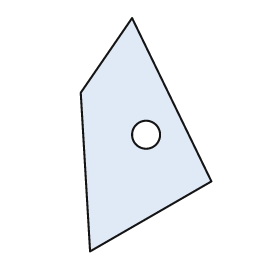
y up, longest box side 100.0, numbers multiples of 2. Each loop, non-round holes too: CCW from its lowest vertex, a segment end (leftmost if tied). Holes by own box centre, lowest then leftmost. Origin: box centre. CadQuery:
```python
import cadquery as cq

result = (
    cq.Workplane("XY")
    .moveTo(-24.0, -50.0)
    .lineTo(28.0, -20.0)
    .lineTo(-6.0, 50.0)
    .lineTo(-28.0, 18.0)
    .close()
    .moveTo(0.0, 0.0)
    .circle(6.0)
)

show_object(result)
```